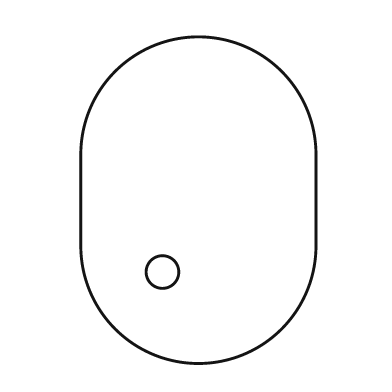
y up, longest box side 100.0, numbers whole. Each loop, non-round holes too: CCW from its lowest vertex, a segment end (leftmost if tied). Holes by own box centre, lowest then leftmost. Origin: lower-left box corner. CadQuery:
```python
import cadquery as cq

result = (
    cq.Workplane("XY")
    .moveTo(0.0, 36.0)
    .threePointArc((36.0, 0.0), (72.0, 36.0))
    .lineTo(72.0, 64.0)
    .threePointArc((36.0, 100.0), (0.0, 64.0))
    .close()
    .moveTo(25.0, 28.0)
    .circle(5.0)
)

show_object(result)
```